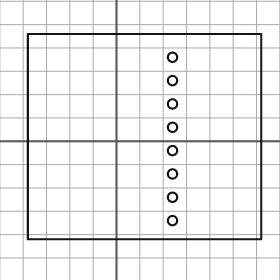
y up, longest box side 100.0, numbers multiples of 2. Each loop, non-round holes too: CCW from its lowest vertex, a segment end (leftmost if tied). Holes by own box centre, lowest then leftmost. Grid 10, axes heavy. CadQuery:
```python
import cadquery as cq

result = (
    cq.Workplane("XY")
    .moveTo(-38.0, -42.0)
    .lineTo(62.0, -42.0)
    .lineTo(62.0, 46.0)
    .lineTo(-38.0, 46.0)
    .close()
    .moveTo(24.0, -34.0)
    .circle(2.0)
    .moveTo(24.0, -24.0)
    .circle(2.0)
    .moveTo(24.0, -14.0)
    .circle(2.0)
    .moveTo(24.0, -4.0)
    .circle(2.0)
    .moveTo(24.0, 6.0)
    .circle(2.0)
    .moveTo(24.0, 16.0)
    .circle(2.0)
    .moveTo(24.0, 26.0)
    .circle(2.0)
    .moveTo(24.0, 36.0)
    .circle(2.0)
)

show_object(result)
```